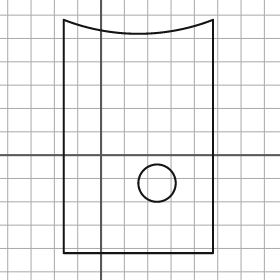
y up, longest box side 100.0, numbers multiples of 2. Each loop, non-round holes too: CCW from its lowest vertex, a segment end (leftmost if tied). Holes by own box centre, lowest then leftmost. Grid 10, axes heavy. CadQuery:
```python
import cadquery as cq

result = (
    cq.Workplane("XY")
    .moveTo(-16.0, -42.0)
    .lineTo(48.0, -42.0)
    .lineTo(48.0, 58.0)
    .threePointArc((16.0, 52.0), (-16.0, 58.0))
    .close()
    .moveTo(24.0, -12.0)
    .circle(8.0)
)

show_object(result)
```